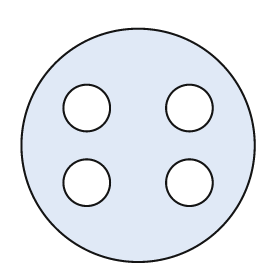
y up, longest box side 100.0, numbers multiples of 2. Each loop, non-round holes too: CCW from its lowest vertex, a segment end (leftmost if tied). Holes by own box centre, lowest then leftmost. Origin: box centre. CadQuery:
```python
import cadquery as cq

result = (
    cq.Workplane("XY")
    .moveTo(0.0, 0.0)
    .circle(50.0)
    .moveTo(-22.0, -16.0)
    .circle(10.0)
    .moveTo(22.0, -16.0)
    .circle(10.0)
    .moveTo(-22.0, 16.0)
    .circle(10.0)
    .moveTo(22.0, 16.0)
    .circle(10.0)
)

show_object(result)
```